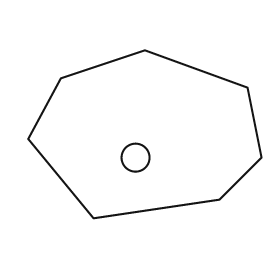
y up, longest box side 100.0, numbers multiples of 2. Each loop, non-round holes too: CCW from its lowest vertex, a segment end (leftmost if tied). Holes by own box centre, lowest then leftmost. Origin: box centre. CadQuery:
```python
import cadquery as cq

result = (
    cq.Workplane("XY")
    .moveTo(-22.0, -36.0)
    .lineTo(32.0, -28.0)
    .lineTo(50.0, -10.0)
    .lineTo(44.0, 20.0)
    .lineTo(0.0, 36.0)
    .lineTo(-36.0, 24.0)
    .lineTo(-50.0, -2.0)
    .close()
    .moveTo(-4.0, -10.0)
    .circle(6.0)
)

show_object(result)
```